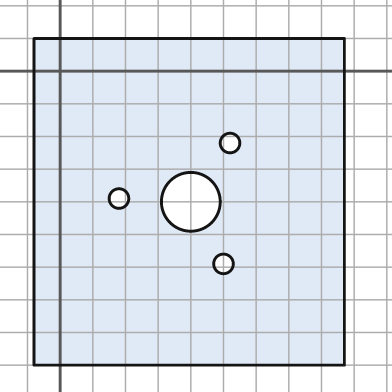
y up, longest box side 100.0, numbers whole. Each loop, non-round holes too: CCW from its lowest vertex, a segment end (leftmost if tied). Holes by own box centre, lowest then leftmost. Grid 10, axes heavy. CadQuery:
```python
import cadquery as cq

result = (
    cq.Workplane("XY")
    .moveTo(-8.0, -90.0)
    .lineTo(87.0, -90.0)
    .lineTo(87.0, 10.0)
    .lineTo(-8.0, 10.0)
    .close()
    .moveTo(50.0, -59.0)
    .circle(3.0)
    .moveTo(40.0, -40.0)
    .circle(9.0)
    .moveTo(18.0, -39.0)
    .circle(3.0)
    .moveTo(52.0, -22.0)
    .circle(3.0)
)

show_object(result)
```